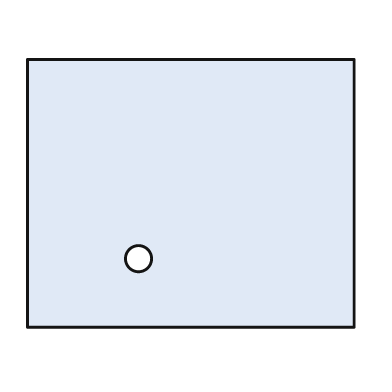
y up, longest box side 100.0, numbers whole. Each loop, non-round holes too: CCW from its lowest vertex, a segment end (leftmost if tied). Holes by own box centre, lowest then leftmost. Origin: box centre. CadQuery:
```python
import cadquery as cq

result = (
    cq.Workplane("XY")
    .moveTo(-50.0, -41.0)
    .lineTo(50.0, -41.0)
    .lineTo(50.0, 41.0)
    .lineTo(-50.0, 41.0)
    .close()
    .moveTo(-16.0, -20.0)
    .circle(4.0)
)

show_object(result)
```